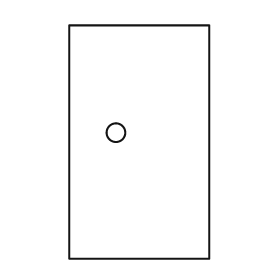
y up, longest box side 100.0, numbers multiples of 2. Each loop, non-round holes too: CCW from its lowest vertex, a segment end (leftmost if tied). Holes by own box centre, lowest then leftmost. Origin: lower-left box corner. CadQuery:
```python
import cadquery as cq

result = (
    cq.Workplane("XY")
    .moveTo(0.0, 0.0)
    .lineTo(60.0, 0.0)
    .lineTo(60.0, 100.0)
    .lineTo(0.0, 100.0)
    .close()
    .moveTo(20.0, 54.0)
    .circle(4.0)
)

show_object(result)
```